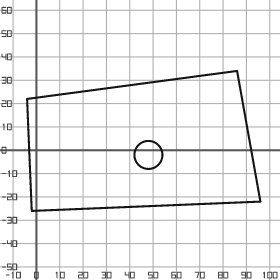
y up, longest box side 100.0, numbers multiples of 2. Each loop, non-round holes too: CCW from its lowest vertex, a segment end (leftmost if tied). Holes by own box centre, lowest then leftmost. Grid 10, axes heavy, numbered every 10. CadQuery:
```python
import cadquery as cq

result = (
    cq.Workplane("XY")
    .moveTo(-2.0, -26.0)
    .lineTo(96.0, -22.0)
    .lineTo(86.0, 34.0)
    .lineTo(-4.0, 22.0)
    .close()
    .moveTo(48.0, -2.0)
    .circle(6.0)
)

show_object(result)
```